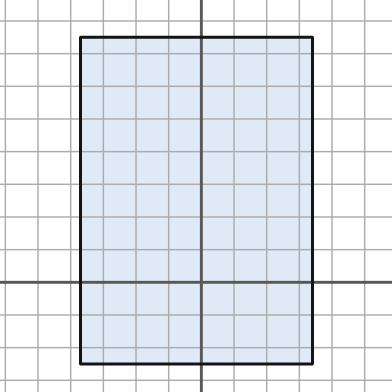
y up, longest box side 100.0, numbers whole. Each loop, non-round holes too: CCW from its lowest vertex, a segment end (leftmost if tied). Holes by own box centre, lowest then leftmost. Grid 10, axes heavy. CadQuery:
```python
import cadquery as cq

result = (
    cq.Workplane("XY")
    .moveTo(-37.0, -25.0)
    .lineTo(34.0, -25.0)
    .lineTo(34.0, 75.0)
    .lineTo(-37.0, 75.0)
    .close()
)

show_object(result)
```